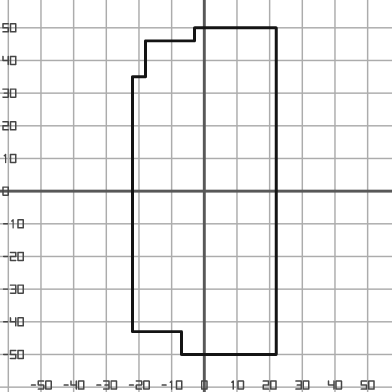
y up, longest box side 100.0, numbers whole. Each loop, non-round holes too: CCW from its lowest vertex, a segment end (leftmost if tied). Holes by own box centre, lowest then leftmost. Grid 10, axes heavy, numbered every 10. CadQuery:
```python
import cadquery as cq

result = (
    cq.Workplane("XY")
    .moveTo(-7.0, -50.0)
    .lineTo(22.0, -50.0)
    .lineTo(22.0, 50.0)
    .lineTo(-3.0, 50.0)
    .lineTo(-3.0, 46.0)
    .lineTo(-18.0, 46.0)
    .lineTo(-18.0, 35.0)
    .lineTo(-22.0, 35.0)
    .lineTo(-22.0, -43.0)
    .lineTo(-7.0, -43.0)
    .close()
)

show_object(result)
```